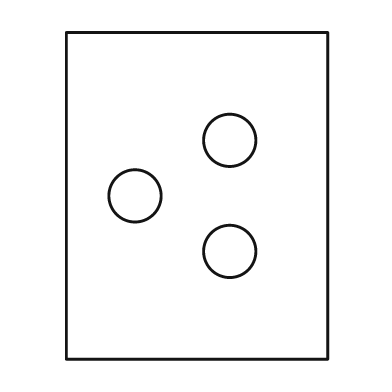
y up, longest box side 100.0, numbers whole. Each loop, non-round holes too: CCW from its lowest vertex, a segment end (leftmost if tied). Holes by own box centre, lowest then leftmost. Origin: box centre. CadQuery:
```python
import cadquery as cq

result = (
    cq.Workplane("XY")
    .moveTo(-40.0, -50.0)
    .lineTo(40.0, -50.0)
    .lineTo(40.0, 50.0)
    .lineTo(-40.0, 50.0)
    .close()
    .moveTo(10.0, -17.0)
    .circle(8.0)
    .moveTo(-19.0, 0.0)
    .circle(8.0)
    .moveTo(10.0, 17.0)
    .circle(8.0)
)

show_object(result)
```